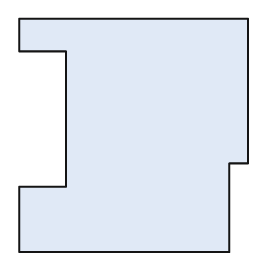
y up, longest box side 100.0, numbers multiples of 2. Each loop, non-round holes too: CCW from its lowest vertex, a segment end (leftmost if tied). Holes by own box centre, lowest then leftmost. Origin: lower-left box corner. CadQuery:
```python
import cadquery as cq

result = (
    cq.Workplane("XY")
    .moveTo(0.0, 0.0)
    .lineTo(90.0, 0.0)
    .lineTo(90.0, 38.0)
    .lineTo(98.0, 38.0)
    .lineTo(98.0, 100.0)
    .lineTo(0.0, 100.0)
    .lineTo(0.0, 86.0)
    .lineTo(20.0, 86.0)
    .lineTo(20.0, 28.0)
    .lineTo(0.0, 28.0)
    .close()
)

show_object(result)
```